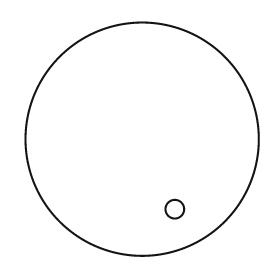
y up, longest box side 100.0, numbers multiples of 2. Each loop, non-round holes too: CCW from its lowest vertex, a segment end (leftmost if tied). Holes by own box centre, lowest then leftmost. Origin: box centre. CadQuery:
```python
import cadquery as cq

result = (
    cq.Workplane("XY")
    .moveTo(0.0, 0.0)
    .circle(50.0)
    .moveTo(14.0, -30.0)
    .circle(4.0)
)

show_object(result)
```